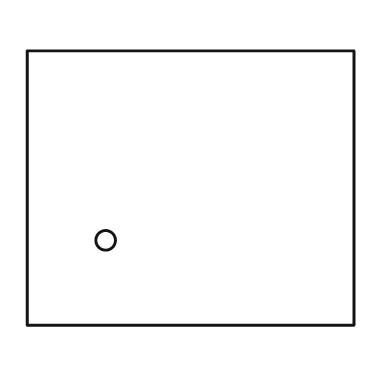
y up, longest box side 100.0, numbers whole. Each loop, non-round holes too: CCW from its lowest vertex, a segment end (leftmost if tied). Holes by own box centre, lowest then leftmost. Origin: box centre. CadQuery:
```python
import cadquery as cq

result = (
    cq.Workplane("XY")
    .moveTo(-50.0, -42.0)
    .lineTo(50.0, -42.0)
    .lineTo(50.0, 42.0)
    .lineTo(-50.0, 42.0)
    .close()
    .moveTo(-26.0, -16.0)
    .circle(3.0)
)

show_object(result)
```